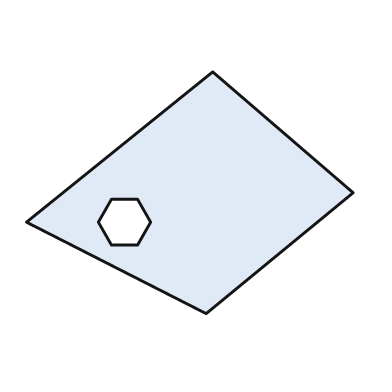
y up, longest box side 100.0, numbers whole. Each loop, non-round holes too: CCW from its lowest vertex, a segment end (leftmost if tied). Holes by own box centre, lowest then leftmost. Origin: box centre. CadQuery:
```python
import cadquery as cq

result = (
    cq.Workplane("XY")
    .moveTo(5.0, -37.0)
    .lineTo(50.0, 0.0)
    .lineTo(7.0, 37.0)
    .lineTo(-50.0, -9.0)
    .close()
    .moveTo(-24.0, -16.0)
    .lineTo(-16.0, -16.0)
    .lineTo(-12.0, -9.0)
    .lineTo(-16.0, -2.0)
    .lineTo(-24.0, -2.0)
    .lineTo(-28.0, -9.0)
    .close()
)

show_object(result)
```